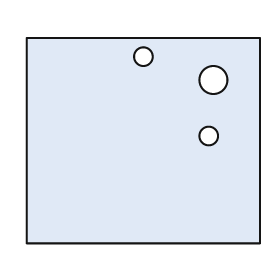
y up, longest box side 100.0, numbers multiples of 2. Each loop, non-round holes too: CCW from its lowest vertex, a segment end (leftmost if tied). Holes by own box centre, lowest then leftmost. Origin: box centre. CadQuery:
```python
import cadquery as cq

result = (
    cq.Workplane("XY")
    .moveTo(-50.0, -44.0)
    .lineTo(50.0, -44.0)
    .lineTo(50.0, 44.0)
    .lineTo(-50.0, 44.0)
    .close()
    .moveTo(28.0, 2.0)
    .circle(4.0)
    .moveTo(30.0, 26.0)
    .circle(6.0)
    .moveTo(0.0, 36.0)
    .circle(4.0)
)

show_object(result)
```